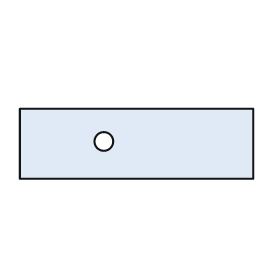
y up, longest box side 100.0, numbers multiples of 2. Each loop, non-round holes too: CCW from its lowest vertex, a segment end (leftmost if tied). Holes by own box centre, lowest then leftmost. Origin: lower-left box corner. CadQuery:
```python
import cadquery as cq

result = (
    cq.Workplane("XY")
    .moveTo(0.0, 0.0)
    .lineTo(100.0, 0.0)
    .lineTo(100.0, 30.0)
    .lineTo(0.0, 30.0)
    .close()
    .moveTo(36.0, 16.0)
    .circle(4.0)
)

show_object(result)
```